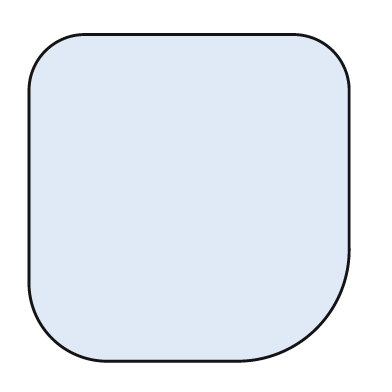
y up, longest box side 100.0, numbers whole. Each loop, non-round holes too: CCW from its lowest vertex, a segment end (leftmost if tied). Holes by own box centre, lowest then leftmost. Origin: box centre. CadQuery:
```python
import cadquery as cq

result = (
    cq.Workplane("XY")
    .moveTo(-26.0, -50.0)
    .lineTo(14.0, -50.0)
    .threePointArc((39.0, -40.0), (49.0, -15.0))
    .lineTo(49.0, 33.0)
    .threePointArc((44.0, 45.0), (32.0, 50.0))
    .lineTo(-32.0, 50.0)
    .threePointArc((-44.0, 45.0), (-49.0, 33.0))
    .lineTo(-49.0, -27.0)
    .threePointArc((-42.0, -43.0), (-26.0, -50.0))
    .close()
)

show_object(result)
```